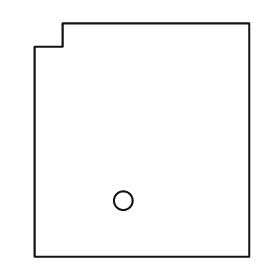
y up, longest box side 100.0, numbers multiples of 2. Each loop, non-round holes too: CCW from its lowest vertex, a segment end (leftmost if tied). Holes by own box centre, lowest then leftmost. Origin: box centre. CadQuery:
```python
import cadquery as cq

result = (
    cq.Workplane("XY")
    .moveTo(-46.0, -50.0)
    .lineTo(46.0, -50.0)
    .lineTo(46.0, 50.0)
    .lineTo(-34.0, 50.0)
    .lineTo(-34.0, 40.0)
    .lineTo(-46.0, 40.0)
    .close()
    .moveTo(-8.0, -26.0)
    .circle(4.0)
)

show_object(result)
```